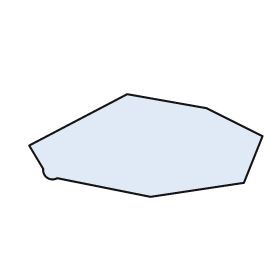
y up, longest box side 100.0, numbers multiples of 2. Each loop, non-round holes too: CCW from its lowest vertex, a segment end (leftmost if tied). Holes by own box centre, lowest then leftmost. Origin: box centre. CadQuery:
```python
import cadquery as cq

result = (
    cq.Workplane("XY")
    .moveTo(2.0, -22.0)
    .lineTo(42.0, -16.0)
    .lineTo(50.0, 4.0)
    .lineTo(26.0, 16.0)
    .lineTo(-8.0, 22.0)
    .lineTo(-50.0, 0.0)
    .lineTo(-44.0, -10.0)
    .threePointArc((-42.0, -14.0), (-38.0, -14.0))
    .close()
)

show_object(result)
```